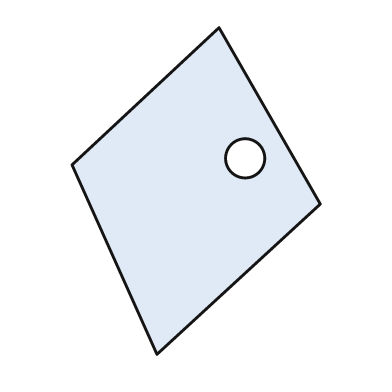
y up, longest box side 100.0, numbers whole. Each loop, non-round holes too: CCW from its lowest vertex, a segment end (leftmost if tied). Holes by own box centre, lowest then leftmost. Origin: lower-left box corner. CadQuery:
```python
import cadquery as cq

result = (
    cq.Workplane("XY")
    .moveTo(26.0, 0.0)
    .lineTo(76.0, 46.0)
    .lineTo(45.0, 100.0)
    .lineTo(0.0, 58.0)
    .close()
    .moveTo(53.0, 60.0)
    .circle(6.0)
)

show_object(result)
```